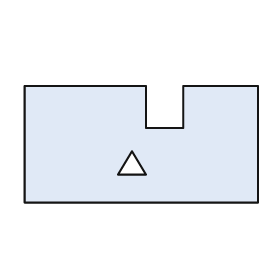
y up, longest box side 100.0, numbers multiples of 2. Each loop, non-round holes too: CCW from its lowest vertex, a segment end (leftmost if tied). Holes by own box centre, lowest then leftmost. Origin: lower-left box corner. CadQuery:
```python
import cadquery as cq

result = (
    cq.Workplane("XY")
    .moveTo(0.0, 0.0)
    .lineTo(100.0, 0.0)
    .lineTo(100.0, 50.0)
    .lineTo(68.0, 50.0)
    .lineTo(68.0, 32.0)
    .lineTo(52.0, 32.0)
    .lineTo(52.0, 50.0)
    .lineTo(0.0, 50.0)
    .close()
    .moveTo(40.0, 12.0)
    .lineTo(52.0, 12.0)
    .lineTo(46.0, 22.0)
    .close()
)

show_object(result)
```